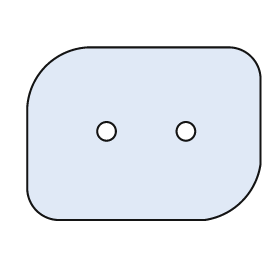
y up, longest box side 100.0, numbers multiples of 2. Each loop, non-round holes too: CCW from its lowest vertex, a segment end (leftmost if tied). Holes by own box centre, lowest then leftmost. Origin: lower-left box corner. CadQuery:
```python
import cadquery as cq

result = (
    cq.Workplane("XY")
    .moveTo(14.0, 0.0)
    .lineTo(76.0, 0.0)
    .threePointArc((92.0, 8.0), (100.0, 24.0))
    .lineTo(100.0, 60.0)
    .threePointArc((96.0, 70.0), (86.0, 74.0))
    .lineTo(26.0, 74.0)
    .threePointArc((8.0, 66.0), (0.0, 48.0))
    .lineTo(0.0, 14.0)
    .threePointArc((4.0, 4.0), (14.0, 0.0))
    .close()
    .moveTo(34.0, 38.0)
    .circle(4.0)
    .moveTo(68.0, 38.0)
    .circle(4.0)
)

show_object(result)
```